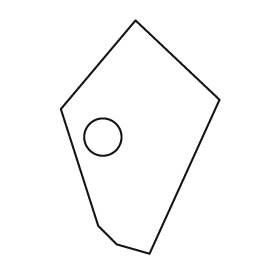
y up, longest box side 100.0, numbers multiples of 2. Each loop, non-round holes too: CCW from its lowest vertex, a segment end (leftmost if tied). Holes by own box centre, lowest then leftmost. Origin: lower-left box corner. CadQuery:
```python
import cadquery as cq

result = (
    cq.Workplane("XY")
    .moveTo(38.0, 0.0)
    .lineTo(68.0, 66.0)
    .lineTo(32.0, 100.0)
    .lineTo(0.0, 62.0)
    .lineTo(16.0, 12.0)
    .lineTo(24.0, 4.0)
    .close()
    .moveTo(18.0, 50.0)
    .circle(8.0)
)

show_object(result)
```